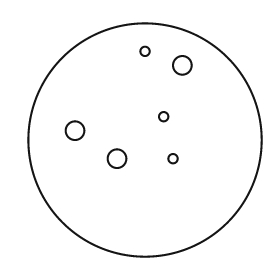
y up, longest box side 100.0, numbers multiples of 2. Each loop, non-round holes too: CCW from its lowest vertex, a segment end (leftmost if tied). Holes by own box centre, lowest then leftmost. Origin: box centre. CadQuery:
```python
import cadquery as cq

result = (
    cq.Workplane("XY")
    .moveTo(0.0, 0.0)
    .circle(50.0)
    .moveTo(-12.0, -8.0)
    .circle(4.0)
    .moveTo(12.0, -8.0)
    .circle(2.0)
    .moveTo(-30.0, 4.0)
    .circle(4.0)
    .moveTo(8.0, 10.0)
    .circle(2.0)
    .moveTo(16.0, 32.0)
    .circle(4.0)
    .moveTo(0.0, 38.0)
    .circle(2.0)
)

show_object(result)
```